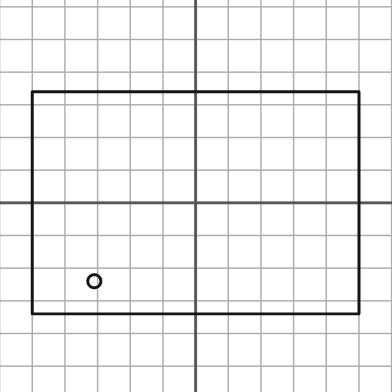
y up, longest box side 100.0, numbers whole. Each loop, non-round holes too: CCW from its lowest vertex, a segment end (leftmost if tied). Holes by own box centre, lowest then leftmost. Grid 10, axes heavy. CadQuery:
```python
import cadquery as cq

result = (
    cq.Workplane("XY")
    .moveTo(-50.0, -34.0)
    .lineTo(50.0, -34.0)
    .lineTo(50.0, 34.0)
    .lineTo(-50.0, 34.0)
    .close()
    .moveTo(-31.0, -24.0)
    .circle(2.0)
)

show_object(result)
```